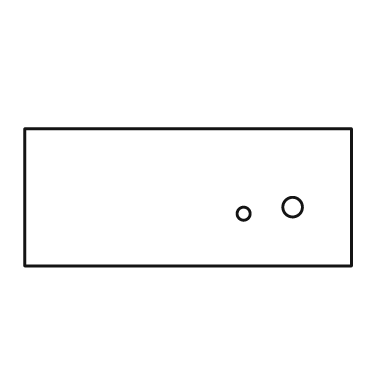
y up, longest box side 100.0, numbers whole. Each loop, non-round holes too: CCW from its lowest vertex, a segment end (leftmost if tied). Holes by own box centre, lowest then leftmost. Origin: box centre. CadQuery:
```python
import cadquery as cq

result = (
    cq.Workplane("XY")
    .moveTo(-50.0, -21.0)
    .lineTo(50.0, -21.0)
    .lineTo(50.0, 21.0)
    .lineTo(-50.0, 21.0)
    .close()
    .moveTo(17.0, -5.0)
    .circle(2.0)
    .moveTo(32.0, -3.0)
    .circle(3.0)
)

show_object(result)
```